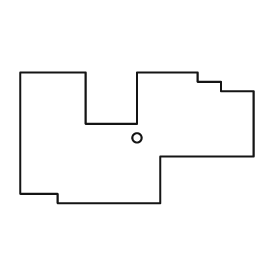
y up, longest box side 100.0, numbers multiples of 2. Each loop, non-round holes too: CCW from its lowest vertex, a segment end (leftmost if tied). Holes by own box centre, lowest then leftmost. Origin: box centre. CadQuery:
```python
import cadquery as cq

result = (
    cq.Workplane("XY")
    .moveTo(-34.0, -28.0)
    .lineTo(10.0, -28.0)
    .lineTo(10.0, -8.0)
    .lineTo(50.0, -8.0)
    .lineTo(50.0, 20.0)
    .lineTo(36.0, 20.0)
    .lineTo(36.0, 24.0)
    .lineTo(26.0, 24.0)
    .lineTo(26.0, 28.0)
    .lineTo(0.0, 28.0)
    .lineTo(0.0, 6.0)
    .lineTo(-22.0, 6.0)
    .lineTo(-22.0, 28.0)
    .lineTo(-50.0, 28.0)
    .lineTo(-50.0, -24.0)
    .lineTo(-34.0, -24.0)
    .close()
    .moveTo(0.0, 0.0)
    .circle(2.0)
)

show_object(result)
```